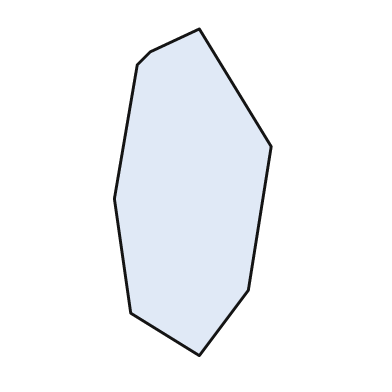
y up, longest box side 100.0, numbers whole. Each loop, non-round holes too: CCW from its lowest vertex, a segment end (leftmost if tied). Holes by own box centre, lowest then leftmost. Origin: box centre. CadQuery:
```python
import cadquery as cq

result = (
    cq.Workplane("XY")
    .moveTo(2.0, -50.0)
    .lineTo(17.0, -30.0)
    .lineTo(24.0, 14.0)
    .lineTo(2.0, 50.0)
    .lineTo(-13.0, 43.0)
    .lineTo(-17.0, 39.0)
    .lineTo(-24.0, -2.0)
    .lineTo(-19.0, -37.0)
    .close()
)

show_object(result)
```